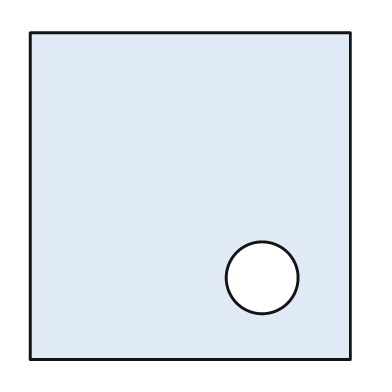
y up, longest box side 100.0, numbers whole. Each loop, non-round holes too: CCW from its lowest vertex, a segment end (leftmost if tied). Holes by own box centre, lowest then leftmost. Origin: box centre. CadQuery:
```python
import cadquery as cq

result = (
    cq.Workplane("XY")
    .moveTo(-49.0, -50.0)
    .lineTo(49.0, -50.0)
    .lineTo(49.0, 50.0)
    .lineTo(-49.0, 50.0)
    .close()
    .moveTo(22.0, -25.0)
    .circle(11.0)
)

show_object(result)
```